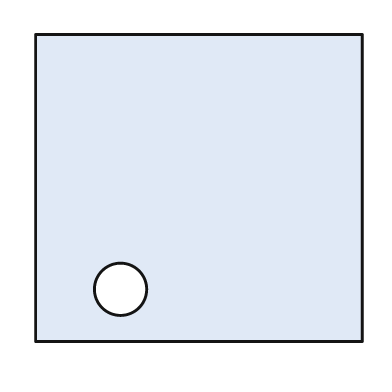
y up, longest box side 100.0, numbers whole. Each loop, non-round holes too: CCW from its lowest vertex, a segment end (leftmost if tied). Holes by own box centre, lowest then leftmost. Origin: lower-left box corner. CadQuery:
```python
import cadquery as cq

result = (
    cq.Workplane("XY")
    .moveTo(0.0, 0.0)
    .lineTo(100.0, 0.0)
    .lineTo(100.0, 94.0)
    .lineTo(0.0, 94.0)
    .close()
    .moveTo(26.0, 16.0)
    .circle(8.0)
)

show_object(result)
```